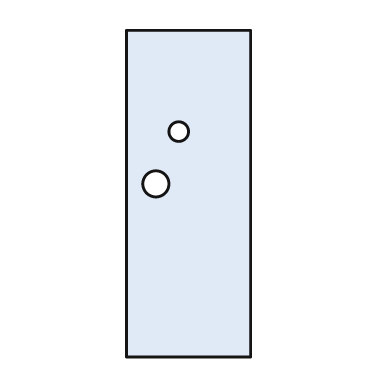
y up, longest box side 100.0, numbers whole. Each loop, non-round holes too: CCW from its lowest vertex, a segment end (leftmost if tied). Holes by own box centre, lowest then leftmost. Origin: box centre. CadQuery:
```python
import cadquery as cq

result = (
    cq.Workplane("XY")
    .moveTo(-19.0, -50.0)
    .lineTo(19.0, -50.0)
    .lineTo(19.0, 50.0)
    .lineTo(-19.0, 50.0)
    .close()
    .moveTo(-10.0, 3.0)
    .circle(4.0)
    .moveTo(-3.0, 19.0)
    .circle(3.0)
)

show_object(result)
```